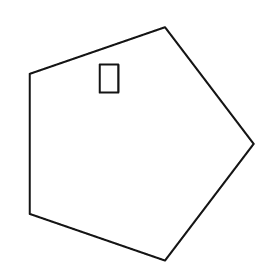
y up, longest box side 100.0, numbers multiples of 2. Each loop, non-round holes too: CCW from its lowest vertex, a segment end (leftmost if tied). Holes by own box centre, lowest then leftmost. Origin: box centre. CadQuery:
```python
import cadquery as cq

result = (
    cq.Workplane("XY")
    .moveTo(10.0, -50.0)
    .lineTo(48.0, 0.0)
    .lineTo(10.0, 50.0)
    .lineTo(-48.0, 30.0)
    .lineTo(-48.0, -30.0)
    .close()
    .moveTo(-18.0, 22.0)
    .lineTo(-10.0, 22.0)
    .lineTo(-10.0, 34.0)
    .lineTo(-18.0, 34.0)
    .close()
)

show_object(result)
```